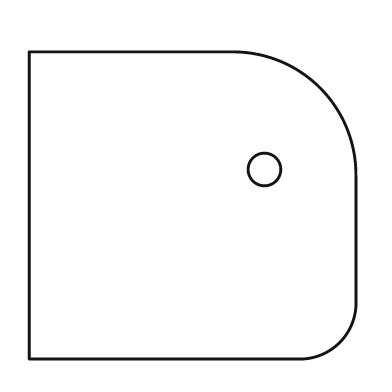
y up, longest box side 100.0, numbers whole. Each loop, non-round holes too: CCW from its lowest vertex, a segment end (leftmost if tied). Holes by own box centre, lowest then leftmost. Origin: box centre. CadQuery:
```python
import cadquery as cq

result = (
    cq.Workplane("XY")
    .moveTo(-50.0, -47.0)
    .lineTo(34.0, -47.0)
    .threePointArc((45.0, -42.0), (50.0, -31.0))
    .lineTo(50.0, 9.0)
    .threePointArc((39.0, 36.0), (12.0, 47.0))
    .lineTo(-50.0, 47.0)
    .close()
    .moveTo(22.0, 11.0)
    .circle(5.0)
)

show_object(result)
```